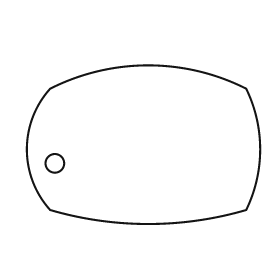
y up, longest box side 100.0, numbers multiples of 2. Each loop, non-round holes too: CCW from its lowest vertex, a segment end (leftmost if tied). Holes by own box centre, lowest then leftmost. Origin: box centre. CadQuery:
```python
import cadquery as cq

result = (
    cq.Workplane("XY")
    .moveTo(-40.0, -28.0)
    .threePointArc((2.0, -34.0), (44.0, -28.0))
    .threePointArc((50.0, -2.0), (44.0, 24.0))
    .threePointArc((2.0, 34.0), (-40.0, 24.0))
    .threePointArc((-50.0, -2.0), (-40.0, -28.0))
    .close()
    .moveTo(-38.0, -8.0)
    .circle(4.0)
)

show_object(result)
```